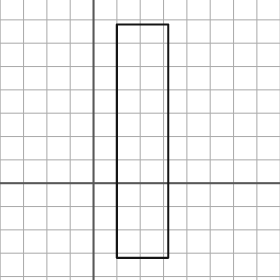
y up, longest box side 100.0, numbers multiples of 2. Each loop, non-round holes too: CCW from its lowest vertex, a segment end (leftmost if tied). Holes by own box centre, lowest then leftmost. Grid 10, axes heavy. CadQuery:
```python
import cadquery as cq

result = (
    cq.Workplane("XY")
    .moveTo(10.0, -32.0)
    .lineTo(32.0, -32.0)
    .lineTo(32.0, 68.0)
    .lineTo(10.0, 68.0)
    .close()
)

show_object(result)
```